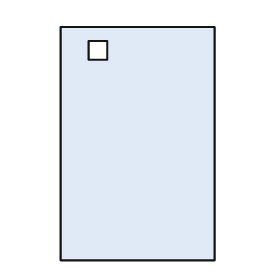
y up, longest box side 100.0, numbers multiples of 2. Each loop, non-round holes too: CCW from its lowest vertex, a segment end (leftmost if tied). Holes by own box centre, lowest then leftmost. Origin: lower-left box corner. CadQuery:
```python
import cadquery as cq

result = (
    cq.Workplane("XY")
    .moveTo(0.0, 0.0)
    .lineTo(66.0, 0.0)
    .lineTo(66.0, 100.0)
    .lineTo(0.0, 100.0)
    .close()
    .moveTo(12.0, 86.0)
    .lineTo(20.0, 86.0)
    .lineTo(20.0, 94.0)
    .lineTo(12.0, 94.0)
    .close()
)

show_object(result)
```